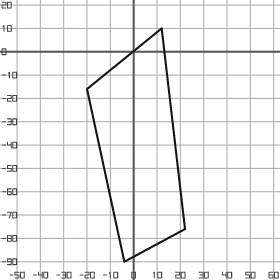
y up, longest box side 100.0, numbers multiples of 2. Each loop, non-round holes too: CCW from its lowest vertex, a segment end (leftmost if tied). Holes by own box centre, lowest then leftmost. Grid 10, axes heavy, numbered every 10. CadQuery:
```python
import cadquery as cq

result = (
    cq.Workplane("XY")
    .moveTo(-4.0, -90.0)
    .lineTo(22.0, -76.0)
    .lineTo(12.0, 10.0)
    .lineTo(-20.0, -16.0)
    .close()
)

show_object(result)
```